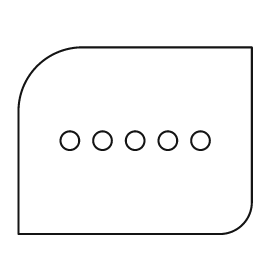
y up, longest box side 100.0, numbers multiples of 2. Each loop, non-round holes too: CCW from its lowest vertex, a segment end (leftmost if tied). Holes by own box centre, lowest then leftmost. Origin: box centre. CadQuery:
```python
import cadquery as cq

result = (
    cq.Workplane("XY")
    .moveTo(-50.0, -40.0)
    .lineTo(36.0, -40.0)
    .threePointArc((46.0, -36.0), (50.0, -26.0))
    .lineTo(50.0, 40.0)
    .lineTo(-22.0, 40.0)
    .threePointArc((-42.0, 32.0), (-50.0, 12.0))
    .close()
    .moveTo(-28.0, 0.0)
    .circle(4.0)
    .moveTo(-14.0, 0.0)
    .circle(4.0)
    .moveTo(0.0, 0.0)
    .circle(4.0)
    .moveTo(14.0, 0.0)
    .circle(4.0)
    .moveTo(28.0, 0.0)
    .circle(4.0)
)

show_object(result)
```